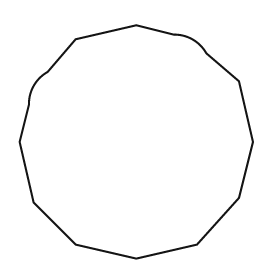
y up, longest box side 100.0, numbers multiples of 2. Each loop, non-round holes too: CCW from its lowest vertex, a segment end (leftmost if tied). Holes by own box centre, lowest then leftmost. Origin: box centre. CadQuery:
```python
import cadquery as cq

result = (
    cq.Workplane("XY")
    .moveTo(0.0, -50.0)
    .lineTo(26.0, -44.0)
    .lineTo(44.0, -24.0)
    .lineTo(50.0, 0.0)
    .lineTo(44.0, 26.0)
    .lineTo(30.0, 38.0)
    .threePointArc((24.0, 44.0), (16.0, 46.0))
    .lineTo(0.0, 50.0)
    .lineTo(-26.0, 44.0)
    .lineTo(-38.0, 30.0)
    .threePointArc((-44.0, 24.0), (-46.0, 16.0))
    .lineTo(-50.0, 0.0)
    .lineTo(-44.0, -26.0)
    .lineTo(-26.0, -44.0)
    .close()
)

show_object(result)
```